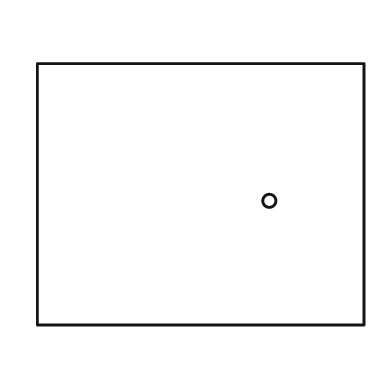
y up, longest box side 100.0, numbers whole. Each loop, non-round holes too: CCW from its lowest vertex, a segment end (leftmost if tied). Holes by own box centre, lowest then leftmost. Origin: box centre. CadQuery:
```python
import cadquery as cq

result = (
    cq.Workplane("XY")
    .moveTo(-50.0, -40.0)
    .lineTo(50.0, -40.0)
    .lineTo(50.0, 40.0)
    .lineTo(-50.0, 40.0)
    .close()
    .moveTo(21.0, -2.0)
    .circle(2.0)
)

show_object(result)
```